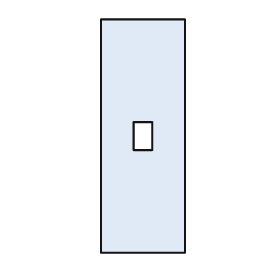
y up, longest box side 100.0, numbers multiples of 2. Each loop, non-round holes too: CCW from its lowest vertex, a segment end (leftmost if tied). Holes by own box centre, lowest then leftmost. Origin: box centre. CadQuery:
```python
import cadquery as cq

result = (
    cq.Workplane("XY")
    .moveTo(-18.0, -50.0)
    .lineTo(18.0, -50.0)
    .lineTo(18.0, 50.0)
    .lineTo(-18.0, 50.0)
    .close()
    .moveTo(-4.0, -6.0)
    .lineTo(4.0, -6.0)
    .lineTo(4.0, 6.0)
    .lineTo(-4.0, 6.0)
    .close()
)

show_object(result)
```